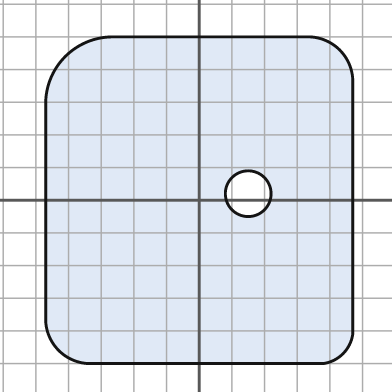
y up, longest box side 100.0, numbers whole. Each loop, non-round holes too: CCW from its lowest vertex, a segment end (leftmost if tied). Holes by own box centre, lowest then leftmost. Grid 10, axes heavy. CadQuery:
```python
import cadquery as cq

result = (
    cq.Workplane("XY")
    .moveTo(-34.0, -50.0)
    .lineTo(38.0, -50.0)
    .threePointArc((44.0, -47.0), (47.0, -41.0))
    .lineTo(47.0, 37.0)
    .threePointArc((43.0, 46.0), (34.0, 50.0))
    .lineTo(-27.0, 50.0)
    .threePointArc((-41.0, 44.0), (-47.0, 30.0))
    .lineTo(-47.0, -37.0)
    .threePointArc((-43.0, -46.0), (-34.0, -50.0))
    .close()
    .moveTo(15.0, 2.0)
    .circle(7.0)
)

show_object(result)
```